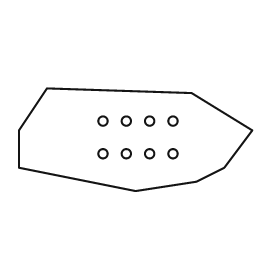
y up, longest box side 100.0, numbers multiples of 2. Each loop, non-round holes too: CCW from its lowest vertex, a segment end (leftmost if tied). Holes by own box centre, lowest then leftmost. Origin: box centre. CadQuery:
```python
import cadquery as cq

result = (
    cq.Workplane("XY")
    .moveTo(0.0, -22.0)
    .lineTo(26.0, -18.0)
    .lineTo(38.0, -12.0)
    .lineTo(50.0, 4.0)
    .lineTo(24.0, 20.0)
    .lineTo(-38.0, 22.0)
    .lineTo(-50.0, 4.0)
    .lineTo(-50.0, -12.0)
    .close()
    .moveTo(-14.0, -6.0)
    .circle(2.0)
    .moveTo(-4.0, -6.0)
    .circle(2.0)
    .moveTo(6.0, -6.0)
    .circle(2.0)
    .moveTo(16.0, -6.0)
    .circle(2.0)
    .moveTo(-14.0, 8.0)
    .circle(2.0)
    .moveTo(-4.0, 8.0)
    .circle(2.0)
    .moveTo(6.0, 8.0)
    .circle(2.0)
    .moveTo(16.0, 8.0)
    .circle(2.0)
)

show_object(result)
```